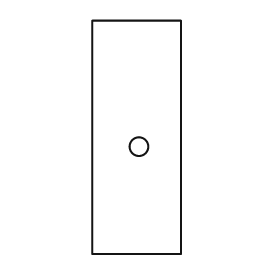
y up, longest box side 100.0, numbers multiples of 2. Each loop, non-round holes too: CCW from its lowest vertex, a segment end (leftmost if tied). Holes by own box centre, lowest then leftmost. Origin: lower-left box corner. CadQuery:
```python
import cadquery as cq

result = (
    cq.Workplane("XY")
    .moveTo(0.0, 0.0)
    .lineTo(38.0, 0.0)
    .lineTo(38.0, 100.0)
    .lineTo(0.0, 100.0)
    .close()
    .moveTo(20.0, 46.0)
    .circle(4.0)
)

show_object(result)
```